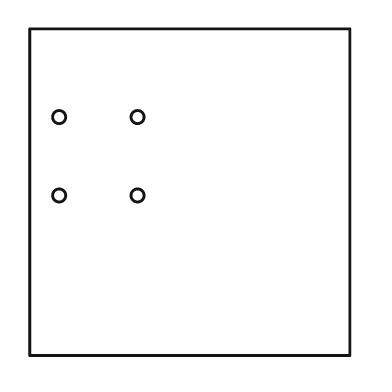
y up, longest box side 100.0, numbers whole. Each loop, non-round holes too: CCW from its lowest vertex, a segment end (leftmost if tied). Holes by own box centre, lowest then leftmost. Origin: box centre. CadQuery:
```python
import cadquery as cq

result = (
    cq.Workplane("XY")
    .moveTo(-49.0, -50.0)
    .lineTo(49.0, -50.0)
    .lineTo(49.0, 50.0)
    .lineTo(-49.0, 50.0)
    .close()
    .moveTo(-40.0, -1.0)
    .circle(2.0)
    .moveTo(-16.0, -1.0)
    .circle(2.0)
    .moveTo(-40.0, 23.0)
    .circle(2.0)
    .moveTo(-16.0, 23.0)
    .circle(2.0)
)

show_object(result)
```